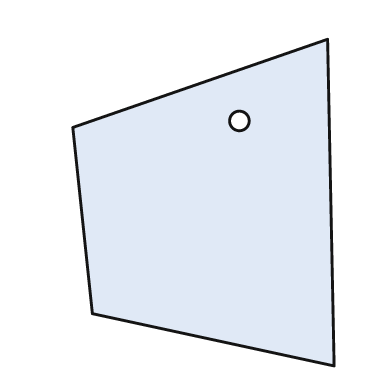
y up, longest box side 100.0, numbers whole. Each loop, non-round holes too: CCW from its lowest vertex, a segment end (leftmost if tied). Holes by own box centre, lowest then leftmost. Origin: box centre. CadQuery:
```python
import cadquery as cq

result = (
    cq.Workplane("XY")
    .moveTo(40.0, -50.0)
    .lineTo(38.0, 50.0)
    .lineTo(-40.0, 23.0)
    .lineTo(-34.0, -34.0)
    .close()
    .moveTo(11.0, 25.0)
    .circle(3.0)
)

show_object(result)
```